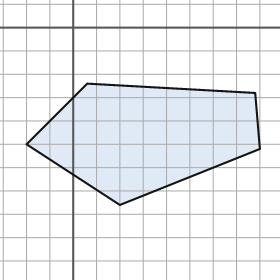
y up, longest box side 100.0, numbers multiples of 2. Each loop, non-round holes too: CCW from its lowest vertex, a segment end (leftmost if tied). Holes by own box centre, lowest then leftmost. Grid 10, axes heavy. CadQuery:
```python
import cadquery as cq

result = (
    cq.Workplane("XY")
    .moveTo(20.0, -76.0)
    .lineTo(80.0, -52.0)
    .lineTo(78.0, -28.0)
    .lineTo(6.0, -24.0)
    .lineTo(-20.0, -50.0)
    .close()
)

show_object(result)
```